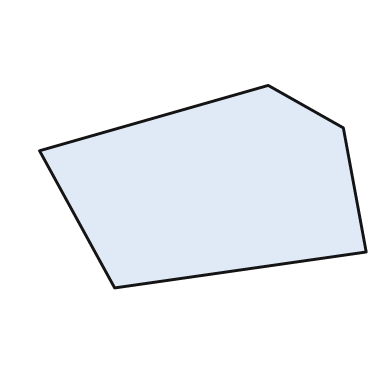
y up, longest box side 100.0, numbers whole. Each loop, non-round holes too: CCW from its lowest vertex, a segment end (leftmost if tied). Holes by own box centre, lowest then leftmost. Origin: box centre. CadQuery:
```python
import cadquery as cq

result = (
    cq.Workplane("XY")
    .moveTo(-27.0, -31.0)
    .lineTo(50.0, -20.0)
    .lineTo(43.0, 18.0)
    .lineTo(20.0, 31.0)
    .lineTo(-50.0, 11.0)
    .close()
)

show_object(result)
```